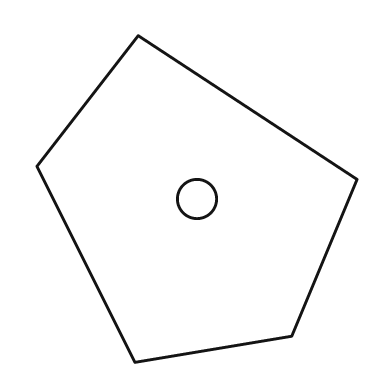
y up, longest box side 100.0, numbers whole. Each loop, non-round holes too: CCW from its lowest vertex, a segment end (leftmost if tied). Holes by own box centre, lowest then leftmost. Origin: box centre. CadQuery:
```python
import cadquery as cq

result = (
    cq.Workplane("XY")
    .moveTo(-19.0, -50.0)
    .lineTo(29.0, -42.0)
    .lineTo(49.0, 6.0)
    .lineTo(-18.0, 50.0)
    .lineTo(-49.0, 10.0)
    .close()
    .moveTo(0.0, 0.0)
    .circle(6.0)
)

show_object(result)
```